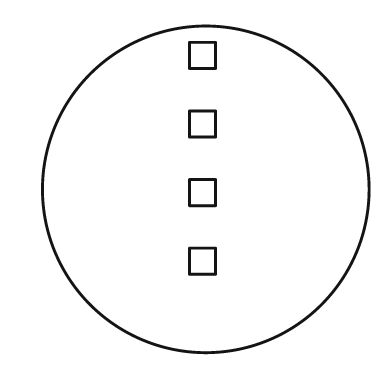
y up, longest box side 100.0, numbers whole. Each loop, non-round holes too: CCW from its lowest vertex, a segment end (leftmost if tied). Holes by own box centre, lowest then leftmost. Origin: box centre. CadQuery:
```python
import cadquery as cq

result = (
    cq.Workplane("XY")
    .moveTo(0.0, 0.0)
    .circle(50.0)
    .moveTo(-5.0, -26.0)
    .lineTo(3.0, -26.0)
    .lineTo(3.0, -18.0)
    .lineTo(-5.0, -18.0)
    .close()
    .moveTo(-5.0, -5.0)
    .lineTo(3.0, -5.0)
    .lineTo(3.0, 3.0)
    .lineTo(-5.0, 3.0)
    .close()
    .moveTo(-5.0, 16.0)
    .lineTo(3.0, 16.0)
    .lineTo(3.0, 24.0)
    .lineTo(-5.0, 24.0)
    .close()
    .moveTo(-5.0, 37.0)
    .lineTo(3.0, 37.0)
    .lineTo(3.0, 45.0)
    .lineTo(-5.0, 45.0)
    .close()
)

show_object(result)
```